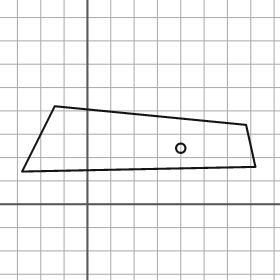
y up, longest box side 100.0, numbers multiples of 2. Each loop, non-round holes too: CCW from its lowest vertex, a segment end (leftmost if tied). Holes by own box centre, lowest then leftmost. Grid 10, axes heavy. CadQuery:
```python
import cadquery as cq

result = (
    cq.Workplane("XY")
    .moveTo(-28.0, 14.0)
    .lineTo(72.0, 16.0)
    .lineTo(68.0, 34.0)
    .lineTo(-14.0, 42.0)
    .close()
    .moveTo(40.0, 24.0)
    .circle(2.0)
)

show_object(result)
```